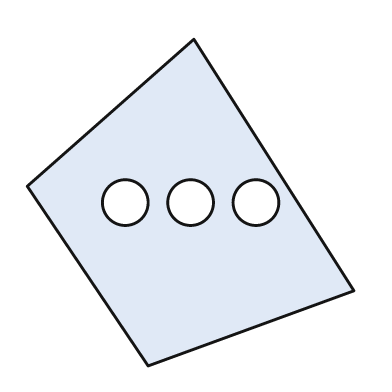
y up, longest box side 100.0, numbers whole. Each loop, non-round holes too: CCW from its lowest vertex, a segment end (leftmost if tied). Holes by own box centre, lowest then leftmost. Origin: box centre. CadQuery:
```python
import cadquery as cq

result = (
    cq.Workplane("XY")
    .moveTo(-13.0, -50.0)
    .lineTo(50.0, -27.0)
    .lineTo(1.0, 50.0)
    .lineTo(-50.0, 5.0)
    .close()
    .moveTo(-20.0, 0.0)
    .circle(7.0)
    .moveTo(0.0, 0.0)
    .circle(7.0)
    .moveTo(20.0, 0.0)
    .circle(7.0)
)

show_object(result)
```